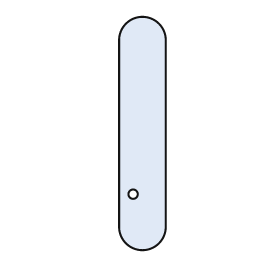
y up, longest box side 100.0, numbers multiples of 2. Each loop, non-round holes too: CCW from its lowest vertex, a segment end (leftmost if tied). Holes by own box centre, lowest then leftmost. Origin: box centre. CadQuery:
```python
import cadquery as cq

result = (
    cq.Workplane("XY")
    .moveTo(-10.0, -40.0)
    .threePointArc((0.0, -50.0), (10.0, -40.0))
    .lineTo(10.0, 40.0)
    .threePointArc((0.0, 50.0), (-10.0, 40.0))
    .close()
    .moveTo(-4.0, -26.0)
    .circle(2.0)
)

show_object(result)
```